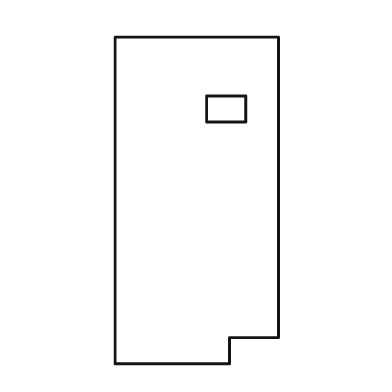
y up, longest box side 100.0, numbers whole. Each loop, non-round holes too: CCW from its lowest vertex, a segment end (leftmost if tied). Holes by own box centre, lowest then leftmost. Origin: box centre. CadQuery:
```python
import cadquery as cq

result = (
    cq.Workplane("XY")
    .moveTo(-25.0, -50.0)
    .lineTo(10.0, -50.0)
    .lineTo(10.0, -42.0)
    .lineTo(25.0, -42.0)
    .lineTo(25.0, 50.0)
    .lineTo(-25.0, 50.0)
    .close()
    .moveTo(3.0, 24.0)
    .lineTo(15.0, 24.0)
    .lineTo(15.0, 32.0)
    .lineTo(3.0, 32.0)
    .close()
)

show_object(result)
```